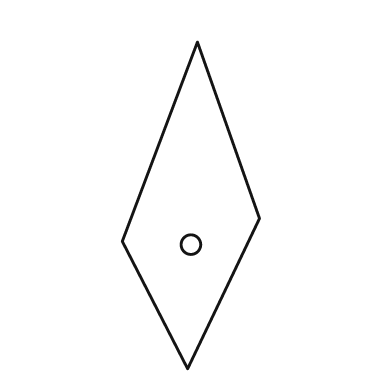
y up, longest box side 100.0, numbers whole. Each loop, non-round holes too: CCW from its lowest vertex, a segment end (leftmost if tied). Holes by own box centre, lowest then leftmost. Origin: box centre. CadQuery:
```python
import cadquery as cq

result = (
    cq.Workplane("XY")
    .moveTo(-1.0, -50.0)
    .lineTo(21.0, -4.0)
    .lineTo(2.0, 50.0)
    .lineTo(-21.0, -11.0)
    .close()
    .moveTo(0.0, -12.0)
    .circle(3.0)
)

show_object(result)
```